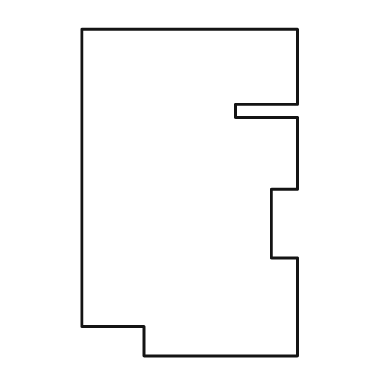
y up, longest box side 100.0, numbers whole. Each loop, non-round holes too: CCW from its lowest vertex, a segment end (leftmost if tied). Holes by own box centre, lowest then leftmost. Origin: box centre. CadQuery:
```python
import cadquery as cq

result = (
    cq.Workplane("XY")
    .moveTo(-14.0, -50.0)
    .lineTo(33.0, -50.0)
    .lineTo(33.0, -20.0)
    .lineTo(25.0, -20.0)
    .lineTo(25.0, 1.0)
    .lineTo(33.0, 1.0)
    .lineTo(33.0, 23.0)
    .lineTo(14.0, 23.0)
    .lineTo(14.0, 27.0)
    .lineTo(33.0, 27.0)
    .lineTo(33.0, 50.0)
    .lineTo(-33.0, 50.0)
    .lineTo(-33.0, -41.0)
    .lineTo(-14.0, -41.0)
    .close()
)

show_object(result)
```